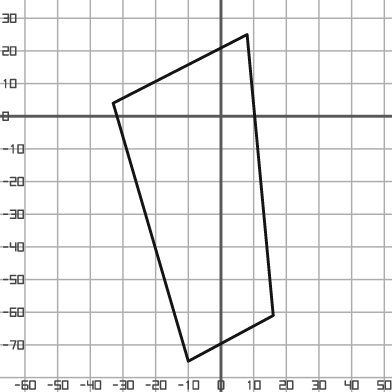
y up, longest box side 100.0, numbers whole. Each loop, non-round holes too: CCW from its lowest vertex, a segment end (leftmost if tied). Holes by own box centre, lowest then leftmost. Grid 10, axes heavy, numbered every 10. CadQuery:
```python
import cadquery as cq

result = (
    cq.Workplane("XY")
    .moveTo(-10.0, -75.0)
    .lineTo(16.0, -61.0)
    .lineTo(8.0, 25.0)
    .lineTo(-33.0, 4.0)
    .close()
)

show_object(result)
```